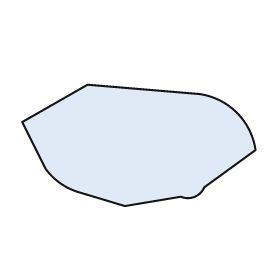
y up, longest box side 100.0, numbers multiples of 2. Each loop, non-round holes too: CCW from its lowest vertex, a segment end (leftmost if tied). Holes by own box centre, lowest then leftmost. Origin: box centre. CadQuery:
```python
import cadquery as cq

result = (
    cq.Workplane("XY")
    .moveTo(-6.0, -26.0)
    .lineTo(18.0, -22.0)
    .threePointArc((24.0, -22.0), (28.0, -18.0))
    .lineTo(50.0, -2.0)
    .threePointArc((42.0, 14.0), (26.0, 22.0))
    .lineTo(-22.0, 26.0)
    .lineTo(-50.0, 10.0)
    .lineTo(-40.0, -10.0)
    .threePointArc((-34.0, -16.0), (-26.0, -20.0))
    .close()
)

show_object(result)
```